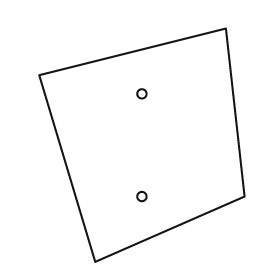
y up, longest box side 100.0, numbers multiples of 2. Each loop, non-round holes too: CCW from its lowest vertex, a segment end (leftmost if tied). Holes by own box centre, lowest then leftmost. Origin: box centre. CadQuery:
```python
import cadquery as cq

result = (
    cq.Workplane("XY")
    .moveTo(-20.0, -50.0)
    .lineTo(44.0, -22.0)
    .lineTo(36.0, 50.0)
    .lineTo(-44.0, 30.0)
    .close()
    .moveTo(0.0, -22.0)
    .circle(2.0)
    .moveTo(0.0, 22.0)
    .circle(2.0)
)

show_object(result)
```